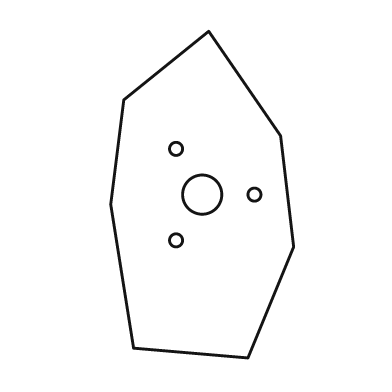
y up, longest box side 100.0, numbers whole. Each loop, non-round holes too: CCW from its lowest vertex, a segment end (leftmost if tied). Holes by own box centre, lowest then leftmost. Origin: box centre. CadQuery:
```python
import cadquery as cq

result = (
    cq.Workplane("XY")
    .moveTo(14.0, -50.0)
    .lineTo(28.0, -16.0)
    .lineTo(24.0, 18.0)
    .lineTo(2.0, 50.0)
    .lineTo(-24.0, 29.0)
    .lineTo(-28.0, -3.0)
    .lineTo(-21.0, -47.0)
    .close()
    .moveTo(-8.0, -14.0)
    .circle(2.0)
    .moveTo(0.0, 0.0)
    .circle(6.0)
    .moveTo(16.0, 0.0)
    .circle(2.0)
    .moveTo(-8.0, 14.0)
    .circle(2.0)
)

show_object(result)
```